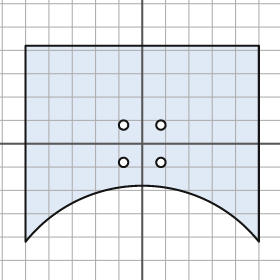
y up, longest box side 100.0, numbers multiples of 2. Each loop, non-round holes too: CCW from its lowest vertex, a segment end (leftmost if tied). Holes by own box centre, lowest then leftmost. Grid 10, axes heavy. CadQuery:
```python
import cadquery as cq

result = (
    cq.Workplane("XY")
    .moveTo(-50.0, -42.0)
    .threePointArc((0.0, -18.0), (50.0, -42.0))
    .lineTo(50.0, 42.0)
    .lineTo(-50.0, 42.0)
    .close()
    .moveTo(-8.0, -8.0)
    .circle(2.0)
    .moveTo(8.0, -8.0)
    .circle(2.0)
    .moveTo(-8.0, 8.0)
    .circle(2.0)
    .moveTo(8.0, 8.0)
    .circle(2.0)
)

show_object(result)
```